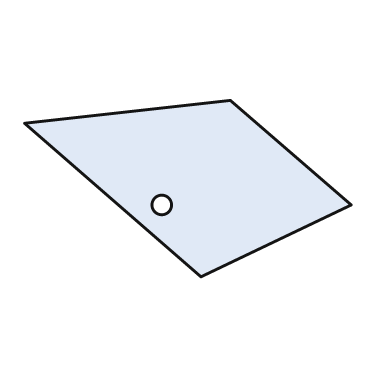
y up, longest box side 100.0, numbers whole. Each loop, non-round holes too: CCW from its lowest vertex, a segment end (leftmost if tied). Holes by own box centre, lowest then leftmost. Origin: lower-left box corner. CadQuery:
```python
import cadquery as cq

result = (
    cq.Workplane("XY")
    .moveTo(54.0, 0.0)
    .lineTo(100.0, 22.0)
    .lineTo(63.0, 54.0)
    .lineTo(0.0, 47.0)
    .close()
    .moveTo(42.0, 22.0)
    .circle(3.0)
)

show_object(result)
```